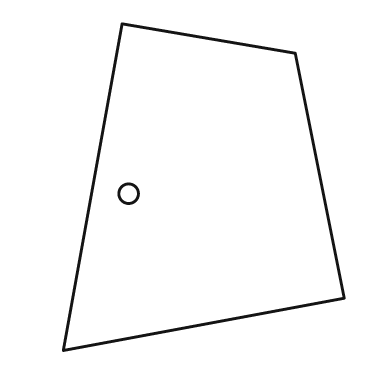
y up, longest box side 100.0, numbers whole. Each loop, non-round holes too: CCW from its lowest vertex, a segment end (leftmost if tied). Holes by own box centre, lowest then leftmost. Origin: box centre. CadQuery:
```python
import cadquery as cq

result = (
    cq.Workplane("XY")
    .moveTo(-43.0, -50.0)
    .lineTo(43.0, -34.0)
    .lineTo(28.0, 41.0)
    .lineTo(-25.0, 50.0)
    .close()
    .moveTo(-23.0, -2.0)
    .circle(3.0)
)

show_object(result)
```